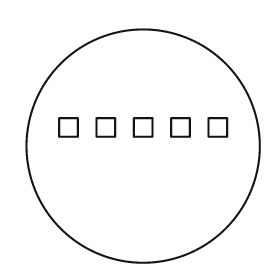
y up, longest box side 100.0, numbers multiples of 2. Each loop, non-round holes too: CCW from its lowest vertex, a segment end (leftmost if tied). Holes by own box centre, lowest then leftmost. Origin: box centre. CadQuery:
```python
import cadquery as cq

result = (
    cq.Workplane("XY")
    .moveTo(0.0, 0.0)
    .circle(50.0)
    .moveTo(-36.0, 4.0)
    .lineTo(-28.0, 4.0)
    .lineTo(-28.0, 12.0)
    .lineTo(-36.0, 12.0)
    .close()
    .moveTo(-20.0, 4.0)
    .lineTo(-12.0, 4.0)
    .lineTo(-12.0, 12.0)
    .lineTo(-20.0, 12.0)
    .close()
    .moveTo(-4.0, 4.0)
    .lineTo(4.0, 4.0)
    .lineTo(4.0, 12.0)
    .lineTo(-4.0, 12.0)
    .close()
    .moveTo(12.0, 4.0)
    .lineTo(20.0, 4.0)
    .lineTo(20.0, 12.0)
    .lineTo(12.0, 12.0)
    .close()
    .moveTo(28.0, 4.0)
    .lineTo(36.0, 4.0)
    .lineTo(36.0, 12.0)
    .lineTo(28.0, 12.0)
    .close()
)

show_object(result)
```